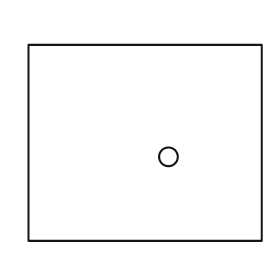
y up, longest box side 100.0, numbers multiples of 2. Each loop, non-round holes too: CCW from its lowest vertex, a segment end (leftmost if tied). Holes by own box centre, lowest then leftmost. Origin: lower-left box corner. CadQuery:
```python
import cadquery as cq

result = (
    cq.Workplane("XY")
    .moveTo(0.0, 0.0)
    .lineTo(100.0, 0.0)
    .lineTo(100.0, 84.0)
    .lineTo(0.0, 84.0)
    .close()
    .moveTo(60.0, 36.0)
    .circle(4.0)
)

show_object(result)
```